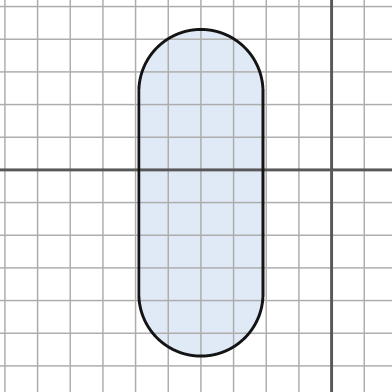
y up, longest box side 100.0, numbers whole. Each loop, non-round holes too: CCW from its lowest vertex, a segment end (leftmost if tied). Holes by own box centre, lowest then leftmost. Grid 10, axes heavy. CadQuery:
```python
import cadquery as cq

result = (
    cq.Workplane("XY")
    .moveTo(-59.0, -38.0)
    .threePointArc((-40.0, -57.0), (-21.0, -38.0))
    .lineTo(-21.0, 24.0)
    .threePointArc((-40.0, 43.0), (-59.0, 24.0))
    .close()
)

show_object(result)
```